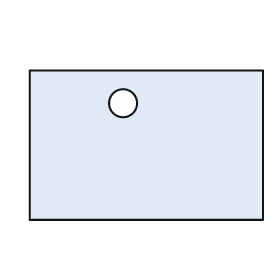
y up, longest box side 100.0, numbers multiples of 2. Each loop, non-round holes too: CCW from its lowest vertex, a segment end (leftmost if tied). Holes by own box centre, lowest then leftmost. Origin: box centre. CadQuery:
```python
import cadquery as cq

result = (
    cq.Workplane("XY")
    .moveTo(-50.0, -32.0)
    .lineTo(50.0, -32.0)
    .lineTo(50.0, 32.0)
    .lineTo(-50.0, 32.0)
    .close()
    .moveTo(-10.0, 18.0)
    .circle(6.0)
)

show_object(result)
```